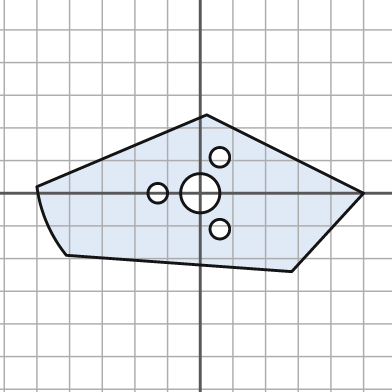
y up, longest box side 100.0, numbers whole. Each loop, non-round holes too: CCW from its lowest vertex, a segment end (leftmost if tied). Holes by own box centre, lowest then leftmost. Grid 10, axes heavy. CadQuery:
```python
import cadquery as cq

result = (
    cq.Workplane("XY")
    .moveTo(28.0, -24.0)
    .lineTo(50.0, 0.0)
    .lineTo(2.0, 24.0)
    .lineTo(-50.0, 2.0)
    .threePointArc((-47.0, -9.0), (-41.0, -19.0))
    .close()
    .moveTo(6.0, -11.0)
    .circle(3.0)
    .moveTo(-13.0, 0.0)
    .circle(3.0)
    .moveTo(0.0, 0.0)
    .circle(6.0)
    .moveTo(6.0, 11.0)
    .circle(3.0)
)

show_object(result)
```